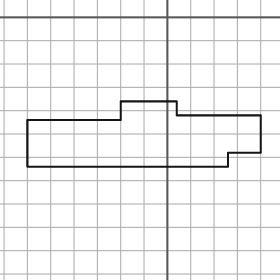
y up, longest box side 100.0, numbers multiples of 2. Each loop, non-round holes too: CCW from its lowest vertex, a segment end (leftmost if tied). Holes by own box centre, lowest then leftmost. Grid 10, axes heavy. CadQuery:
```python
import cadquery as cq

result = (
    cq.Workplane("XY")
    .moveTo(-60.0, -64.0)
    .lineTo(26.0, -64.0)
    .lineTo(26.0, -58.0)
    .lineTo(40.0, -58.0)
    .lineTo(40.0, -42.0)
    .lineTo(4.0, -42.0)
    .lineTo(4.0, -36.0)
    .lineTo(-20.0, -36.0)
    .lineTo(-20.0, -44.0)
    .lineTo(-60.0, -44.0)
    .close()
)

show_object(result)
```